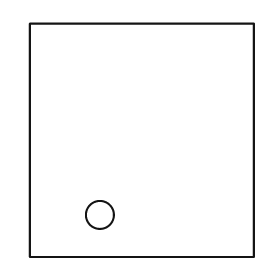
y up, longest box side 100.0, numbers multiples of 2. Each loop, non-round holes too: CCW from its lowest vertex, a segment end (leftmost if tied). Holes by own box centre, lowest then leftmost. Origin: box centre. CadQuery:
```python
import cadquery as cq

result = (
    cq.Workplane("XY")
    .moveTo(-48.0, -50.0)
    .lineTo(48.0, -50.0)
    .lineTo(48.0, 50.0)
    .lineTo(-48.0, 50.0)
    .close()
    .moveTo(-18.0, -32.0)
    .circle(6.0)
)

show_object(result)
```